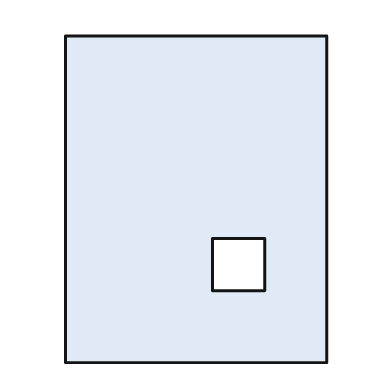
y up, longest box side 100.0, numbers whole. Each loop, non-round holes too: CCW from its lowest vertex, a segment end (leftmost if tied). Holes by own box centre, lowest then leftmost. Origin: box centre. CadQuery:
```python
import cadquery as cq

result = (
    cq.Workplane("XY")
    .moveTo(-40.0, -50.0)
    .lineTo(40.0, -50.0)
    .lineTo(40.0, 50.0)
    .lineTo(-40.0, 50.0)
    .close()
    .moveTo(5.0, -28.0)
    .lineTo(21.0, -28.0)
    .lineTo(21.0, -12.0)
    .lineTo(5.0, -12.0)
    .close()
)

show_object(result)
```